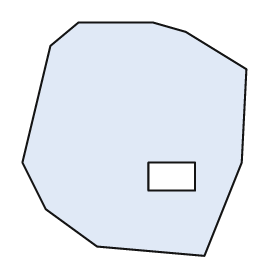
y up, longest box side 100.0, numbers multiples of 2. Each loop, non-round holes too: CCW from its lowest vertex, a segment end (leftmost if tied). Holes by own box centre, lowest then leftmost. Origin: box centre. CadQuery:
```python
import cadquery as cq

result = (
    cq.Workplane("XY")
    .moveTo(30.0, -50.0)
    .lineTo(46.0, -10.0)
    .lineTo(48.0, 30.0)
    .lineTo(22.0, 46.0)
    .lineTo(8.0, 50.0)
    .lineTo(-24.0, 50.0)
    .lineTo(-36.0, 40.0)
    .lineTo(-48.0, -10.0)
    .lineTo(-38.0, -30.0)
    .lineTo(-16.0, -46.0)
    .close()
    .moveTo(6.0, -22.0)
    .lineTo(26.0, -22.0)
    .lineTo(26.0, -10.0)
    .lineTo(6.0, -10.0)
    .close()
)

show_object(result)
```